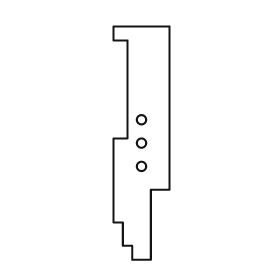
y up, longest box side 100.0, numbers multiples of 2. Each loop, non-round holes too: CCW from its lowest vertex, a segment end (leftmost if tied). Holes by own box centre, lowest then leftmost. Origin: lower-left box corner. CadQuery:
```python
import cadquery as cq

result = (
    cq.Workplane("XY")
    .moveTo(8.0, 0.0)
    .lineTo(16.0, 0.0)
    .lineTo(16.0, 30.0)
    .lineTo(24.0, 30.0)
    .lineTo(24.0, 100.0)
    .lineTo(0.0, 100.0)
    .lineTo(0.0, 94.0)
    .lineTo(6.0, 94.0)
    .lineTo(6.0, 52.0)
    .lineTo(0.0, 52.0)
    .lineTo(0.0, 16.0)
    .lineTo(4.0, 16.0)
    .lineTo(4.0, 6.0)
    .lineTo(8.0, 6.0)
    .close()
    .moveTo(12.0, 40.0)
    .circle(2.0)
    .moveTo(12.0, 50.0)
    .circle(2.0)
    .moveTo(12.0, 60.0)
    .circle(2.0)
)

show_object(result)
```